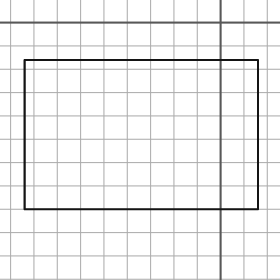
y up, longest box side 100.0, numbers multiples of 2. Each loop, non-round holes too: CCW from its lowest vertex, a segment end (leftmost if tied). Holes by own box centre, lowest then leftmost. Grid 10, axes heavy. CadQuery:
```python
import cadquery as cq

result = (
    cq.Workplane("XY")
    .moveTo(-84.0, -80.0)
    .lineTo(16.0, -80.0)
    .lineTo(16.0, -16.0)
    .lineTo(-84.0, -16.0)
    .close()
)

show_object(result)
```